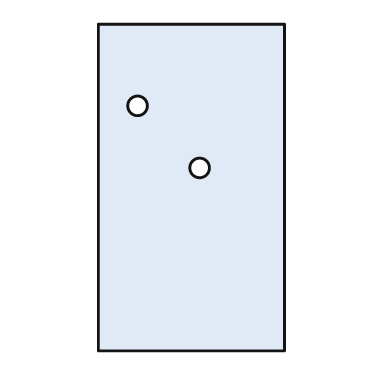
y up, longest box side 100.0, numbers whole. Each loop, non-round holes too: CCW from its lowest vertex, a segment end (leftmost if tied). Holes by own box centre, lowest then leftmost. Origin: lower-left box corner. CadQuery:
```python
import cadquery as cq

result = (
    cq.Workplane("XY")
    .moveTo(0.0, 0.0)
    .lineTo(57.0, 0.0)
    .lineTo(57.0, 100.0)
    .lineTo(0.0, 100.0)
    .close()
    .moveTo(31.0, 56.0)
    .circle(3.0)
    .moveTo(12.0, 75.0)
    .circle(3.0)
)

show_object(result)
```